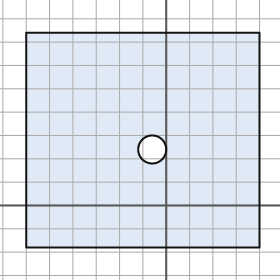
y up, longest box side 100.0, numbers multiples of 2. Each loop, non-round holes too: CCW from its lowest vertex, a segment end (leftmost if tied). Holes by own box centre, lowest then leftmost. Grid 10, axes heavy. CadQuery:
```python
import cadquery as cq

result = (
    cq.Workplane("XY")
    .moveTo(-60.0, -18.0)
    .lineTo(40.0, -18.0)
    .lineTo(40.0, 74.0)
    .lineTo(-60.0, 74.0)
    .close()
    .moveTo(-6.0, 24.0)
    .circle(6.0)
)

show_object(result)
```